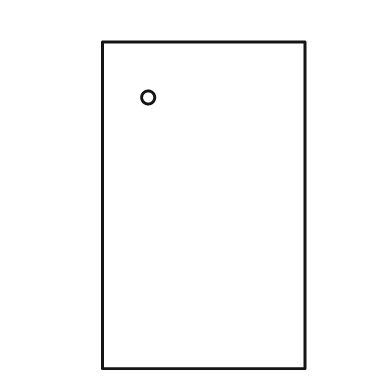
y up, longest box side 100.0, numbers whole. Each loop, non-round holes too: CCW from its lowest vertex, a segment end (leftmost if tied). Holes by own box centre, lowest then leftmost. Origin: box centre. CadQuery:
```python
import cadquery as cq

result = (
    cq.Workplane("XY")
    .moveTo(-31.0, -50.0)
    .lineTo(31.0, -50.0)
    .lineTo(31.0, 50.0)
    .lineTo(-31.0, 50.0)
    .close()
    .moveTo(-17.0, 33.0)
    .circle(2.0)
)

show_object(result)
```